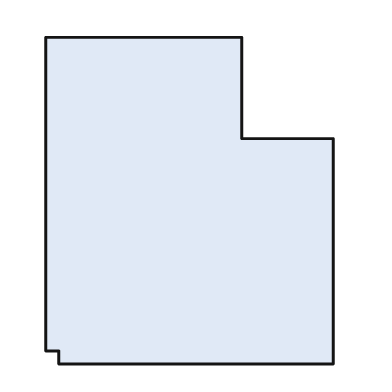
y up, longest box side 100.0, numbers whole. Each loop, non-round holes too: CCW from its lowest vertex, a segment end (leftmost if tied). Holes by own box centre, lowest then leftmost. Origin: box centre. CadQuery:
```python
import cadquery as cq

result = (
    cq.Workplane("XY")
    .moveTo(-40.0, -50.0)
    .lineTo(44.0, -50.0)
    .lineTo(44.0, 19.0)
    .lineTo(16.0, 19.0)
    .lineTo(16.0, 50.0)
    .lineTo(-44.0, 50.0)
    .lineTo(-44.0, -46.0)
    .lineTo(-40.0, -46.0)
    .close()
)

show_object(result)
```